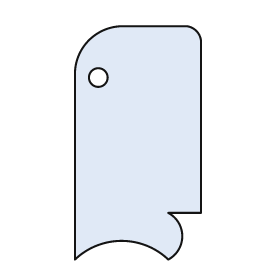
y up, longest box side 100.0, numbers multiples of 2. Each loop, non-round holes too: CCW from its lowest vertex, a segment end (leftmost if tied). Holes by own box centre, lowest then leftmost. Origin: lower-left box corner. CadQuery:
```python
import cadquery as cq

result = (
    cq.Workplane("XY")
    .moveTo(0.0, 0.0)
    .threePointArc((20.0, 8.0), (40.0, 0.0))
    .threePointArc((46.0, 10.0), (40.0, 20.0))
    .lineTo(54.0, 20.0)
    .lineTo(54.0, 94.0)
    .threePointArc((52.0, 98.0), (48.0, 100.0))
    .lineTo(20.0, 100.0)
    .threePointArc((6.0, 94.0), (0.0, 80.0))
    .close()
    .moveTo(10.0, 78.0)
    .circle(4.0)
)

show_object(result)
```